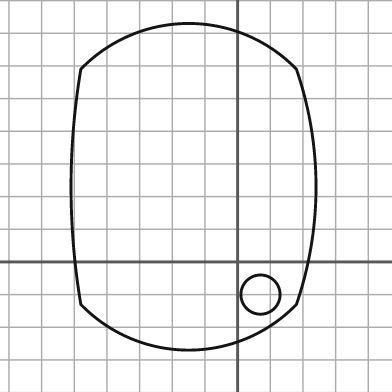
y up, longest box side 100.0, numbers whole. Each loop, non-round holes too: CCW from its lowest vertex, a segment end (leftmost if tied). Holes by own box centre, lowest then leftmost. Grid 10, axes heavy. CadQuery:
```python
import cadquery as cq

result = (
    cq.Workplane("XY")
    .moveTo(-48.0, -13.0)
    .threePointArc((-15.0, -27.0), (18.0, -13.0))
    .threePointArc((24.0, 23.0), (18.0, 59.0))
    .threePointArc((-15.0, 73.0), (-48.0, 59.0))
    .threePointArc((-51.0, 23.0), (-48.0, -13.0))
    .close()
    .moveTo(7.0, -10.0)
    .circle(6.0)
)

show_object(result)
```